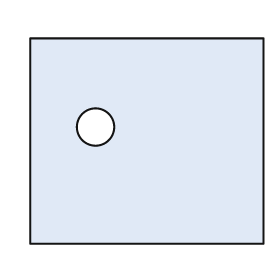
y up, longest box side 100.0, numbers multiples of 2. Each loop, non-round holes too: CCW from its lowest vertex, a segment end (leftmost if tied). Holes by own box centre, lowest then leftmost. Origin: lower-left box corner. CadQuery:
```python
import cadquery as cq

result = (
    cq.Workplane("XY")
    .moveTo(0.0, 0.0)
    .lineTo(100.0, 0.0)
    .lineTo(100.0, 88.0)
    .lineTo(0.0, 88.0)
    .close()
    .moveTo(28.0, 50.0)
    .circle(8.0)
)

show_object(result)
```